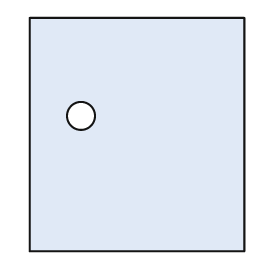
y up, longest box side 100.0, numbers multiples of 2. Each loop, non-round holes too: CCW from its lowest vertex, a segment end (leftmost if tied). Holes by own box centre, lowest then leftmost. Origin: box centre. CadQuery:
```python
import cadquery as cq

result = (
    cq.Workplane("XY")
    .moveTo(-46.0, -50.0)
    .lineTo(46.0, -50.0)
    .lineTo(46.0, 50.0)
    .lineTo(-46.0, 50.0)
    .close()
    .moveTo(-24.0, 8.0)
    .circle(6.0)
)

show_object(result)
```